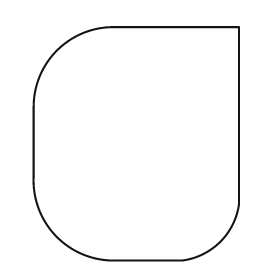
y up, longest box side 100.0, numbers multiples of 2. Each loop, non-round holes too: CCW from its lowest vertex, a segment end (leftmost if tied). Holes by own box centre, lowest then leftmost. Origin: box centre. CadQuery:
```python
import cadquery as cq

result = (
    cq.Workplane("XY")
    .moveTo(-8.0, -50.0)
    .lineTo(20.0, -50.0)
    .threePointArc((36.0, -42.0), (44.0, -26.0))
    .lineTo(44.0, 50.0)
    .lineTo(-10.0, 50.0)
    .threePointArc((-34.0, 40.0), (-44.0, 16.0))
    .lineTo(-44.0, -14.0)
    .threePointArc((-34.0, -40.0), (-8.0, -50.0))
    .close()
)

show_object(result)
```